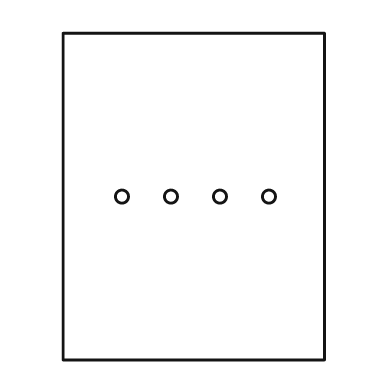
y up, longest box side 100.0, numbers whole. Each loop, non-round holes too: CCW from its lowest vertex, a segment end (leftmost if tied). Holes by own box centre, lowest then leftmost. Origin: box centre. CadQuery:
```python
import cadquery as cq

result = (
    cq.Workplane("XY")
    .moveTo(-40.0, -50.0)
    .lineTo(40.0, -50.0)
    .lineTo(40.0, 50.0)
    .lineTo(-40.0, 50.0)
    .close()
    .moveTo(-22.0, 0.0)
    .circle(2.0)
    .moveTo(-7.0, 0.0)
    .circle(2.0)
    .moveTo(8.0, 0.0)
    .circle(2.0)
    .moveTo(23.0, 0.0)
    .circle(2.0)
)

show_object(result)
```